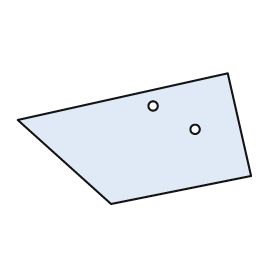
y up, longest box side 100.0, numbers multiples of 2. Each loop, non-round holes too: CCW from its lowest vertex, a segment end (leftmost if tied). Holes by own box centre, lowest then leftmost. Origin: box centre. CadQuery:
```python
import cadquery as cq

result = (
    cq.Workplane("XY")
    .moveTo(-10.0, -28.0)
    .lineTo(50.0, -16.0)
    .lineTo(40.0, 28.0)
    .lineTo(-50.0, 8.0)
    .close()
    .moveTo(26.0, 4.0)
    .circle(2.0)
    .moveTo(8.0, 14.0)
    .circle(2.0)
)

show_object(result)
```